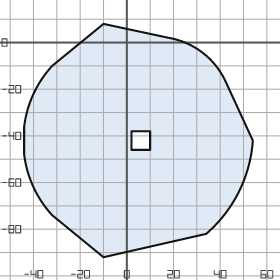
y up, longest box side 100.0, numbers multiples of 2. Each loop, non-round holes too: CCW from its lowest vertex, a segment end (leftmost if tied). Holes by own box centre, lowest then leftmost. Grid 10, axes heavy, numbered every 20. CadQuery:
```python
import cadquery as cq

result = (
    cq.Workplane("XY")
    .moveTo(-10.0, -92.0)
    .lineTo(34.0, -82.0)
    .threePointArc((48.0, -64.0), (54.0, -42.0))
    .lineTo(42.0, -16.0)
    .threePointArc((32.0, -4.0), (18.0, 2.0))
    .lineTo(-10.0, 8.0)
    .lineTo(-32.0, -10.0)
    .threePointArc((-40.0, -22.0), (-44.0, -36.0))
    .lineTo(-44.0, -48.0)
    .threePointArc((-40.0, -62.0), (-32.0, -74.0))
    .close()
    .moveTo(2.0, -46.0)
    .lineTo(10.0, -46.0)
    .lineTo(10.0, -38.0)
    .lineTo(2.0, -38.0)
    .close()
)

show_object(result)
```